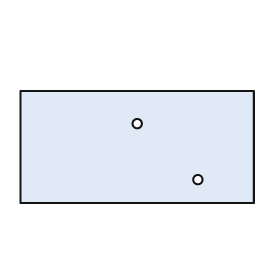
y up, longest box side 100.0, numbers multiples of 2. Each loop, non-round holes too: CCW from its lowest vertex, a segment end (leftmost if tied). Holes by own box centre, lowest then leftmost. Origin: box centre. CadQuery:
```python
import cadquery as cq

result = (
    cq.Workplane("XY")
    .moveTo(-50.0, -24.0)
    .lineTo(50.0, -24.0)
    .lineTo(50.0, 24.0)
    .lineTo(-50.0, 24.0)
    .close()
    .moveTo(26.0, -14.0)
    .circle(2.0)
    .moveTo(0.0, 10.0)
    .circle(2.0)
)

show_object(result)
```